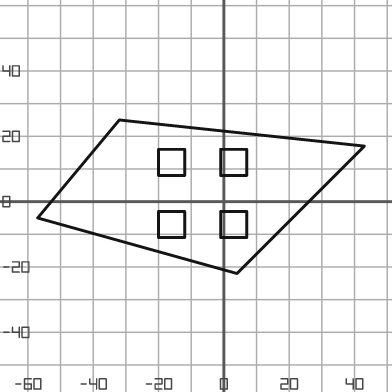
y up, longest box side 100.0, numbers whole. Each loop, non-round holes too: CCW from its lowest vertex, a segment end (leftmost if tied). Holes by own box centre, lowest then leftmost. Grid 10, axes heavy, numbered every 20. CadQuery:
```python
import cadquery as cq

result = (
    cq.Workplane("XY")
    .moveTo(4.0, -22.0)
    .lineTo(43.0, 17.0)
    .lineTo(-32.0, 25.0)
    .lineTo(-57.0, -5.0)
    .close()
    .moveTo(-20.0, -11.0)
    .lineTo(-12.0, -11.0)
    .lineTo(-12.0, -3.0)
    .lineTo(-20.0, -3.0)
    .close()
    .moveTo(-1.0, -11.0)
    .lineTo(7.0, -11.0)
    .lineTo(7.0, -3.0)
    .lineTo(-1.0, -3.0)
    .close()
    .moveTo(-20.0, 8.0)
    .lineTo(-12.0, 8.0)
    .lineTo(-12.0, 16.0)
    .lineTo(-20.0, 16.0)
    .close()
    .moveTo(-1.0, 8.0)
    .lineTo(7.0, 8.0)
    .lineTo(7.0, 16.0)
    .lineTo(-1.0, 16.0)
    .close()
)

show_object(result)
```